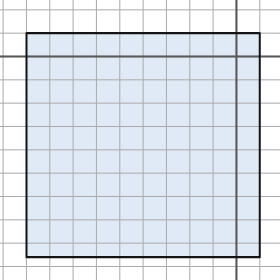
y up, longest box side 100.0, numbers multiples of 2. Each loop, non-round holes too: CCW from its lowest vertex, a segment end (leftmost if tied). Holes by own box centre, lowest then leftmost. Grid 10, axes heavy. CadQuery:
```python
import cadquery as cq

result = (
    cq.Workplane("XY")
    .moveTo(-90.0, -86.0)
    .lineTo(10.0, -86.0)
    .lineTo(10.0, 10.0)
    .lineTo(-90.0, 10.0)
    .close()
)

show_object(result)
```